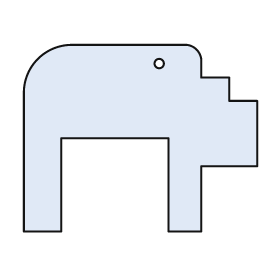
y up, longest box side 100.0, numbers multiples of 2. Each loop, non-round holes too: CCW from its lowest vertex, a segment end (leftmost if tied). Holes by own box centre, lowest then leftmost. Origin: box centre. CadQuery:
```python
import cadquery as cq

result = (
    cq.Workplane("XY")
    .moveTo(-50.0, -40.0)
    .lineTo(-34.0, -40.0)
    .lineTo(-34.0, 0.0)
    .lineTo(12.0, 0.0)
    .lineTo(12.0, -40.0)
    .lineTo(26.0, -40.0)
    .lineTo(26.0, -12.0)
    .lineTo(50.0, -12.0)
    .lineTo(50.0, 16.0)
    .lineTo(38.0, 16.0)
    .lineTo(38.0, 26.0)
    .lineTo(26.0, 26.0)
    .lineTo(26.0, 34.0)
    .threePointArc((24.0, 38.0), (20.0, 40.0))
    .lineTo(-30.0, 40.0)
    .threePointArc((-44.0, 34.0), (-50.0, 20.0))
    .close()
    .moveTo(8.0, 32.0)
    .circle(2.0)
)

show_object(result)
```